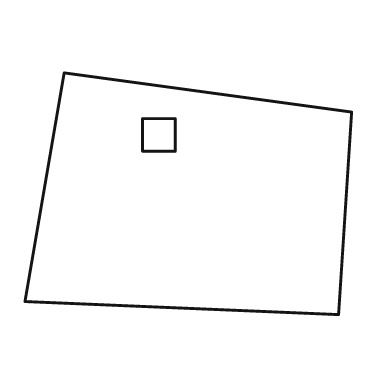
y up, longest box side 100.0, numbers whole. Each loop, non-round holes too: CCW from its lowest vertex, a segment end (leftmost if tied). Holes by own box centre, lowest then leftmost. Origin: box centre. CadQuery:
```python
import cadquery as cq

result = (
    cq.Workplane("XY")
    .moveTo(46.0, -37.0)
    .lineTo(50.0, 25.0)
    .lineTo(-38.0, 37.0)
    .lineTo(-50.0, -33.0)
    .close()
    .moveTo(-14.0, 13.0)
    .lineTo(-4.0, 13.0)
    .lineTo(-4.0, 23.0)
    .lineTo(-14.0, 23.0)
    .close()
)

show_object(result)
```